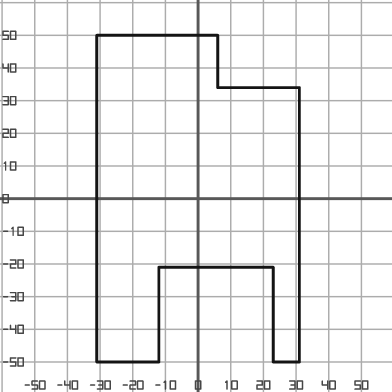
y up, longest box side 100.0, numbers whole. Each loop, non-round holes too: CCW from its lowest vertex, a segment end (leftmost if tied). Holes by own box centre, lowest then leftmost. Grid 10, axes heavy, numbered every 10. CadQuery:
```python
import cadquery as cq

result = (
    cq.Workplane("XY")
    .moveTo(-31.0, -50.0)
    .lineTo(-12.0, -50.0)
    .lineTo(-12.0, -21.0)
    .lineTo(23.0, -21.0)
    .lineTo(23.0, -50.0)
    .lineTo(31.0, -50.0)
    .lineTo(31.0, 34.0)
    .lineTo(6.0, 34.0)
    .lineTo(6.0, 50.0)
    .lineTo(-31.0, 50.0)
    .close()
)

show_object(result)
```